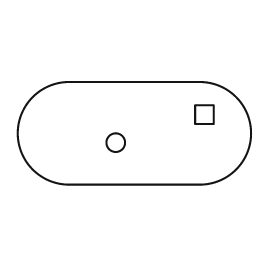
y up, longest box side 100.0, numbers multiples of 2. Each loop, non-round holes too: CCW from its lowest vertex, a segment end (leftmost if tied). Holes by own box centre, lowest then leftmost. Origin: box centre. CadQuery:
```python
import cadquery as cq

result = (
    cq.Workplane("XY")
    .moveTo(-28.0, -22.0)
    .lineTo(28.0, -22.0)
    .threePointArc((50.0, 0.0), (28.0, 22.0))
    .lineTo(-28.0, 22.0)
    .threePointArc((-50.0, 0.0), (-28.0, -22.0))
    .close()
    .moveTo(-8.0, -4.0)
    .circle(4.0)
    .moveTo(26.0, 4.0)
    .lineTo(34.0, 4.0)
    .lineTo(34.0, 12.0)
    .lineTo(26.0, 12.0)
    .close()
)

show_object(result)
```